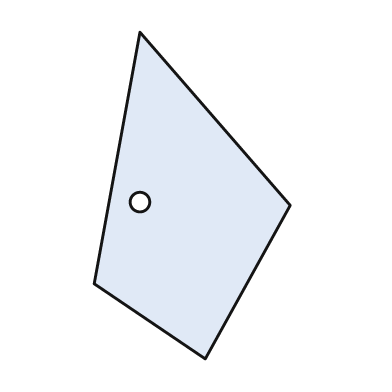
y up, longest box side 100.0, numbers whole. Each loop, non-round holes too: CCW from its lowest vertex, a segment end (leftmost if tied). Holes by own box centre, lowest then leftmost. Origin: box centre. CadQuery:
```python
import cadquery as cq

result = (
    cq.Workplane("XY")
    .moveTo(4.0, -50.0)
    .lineTo(30.0, -3.0)
    .lineTo(-16.0, 50.0)
    .lineTo(-30.0, -27.0)
    .close()
    .moveTo(-16.0, -2.0)
    .circle(3.0)
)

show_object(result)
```